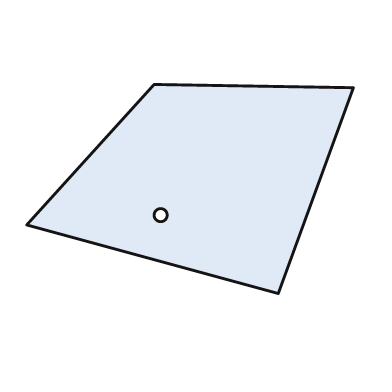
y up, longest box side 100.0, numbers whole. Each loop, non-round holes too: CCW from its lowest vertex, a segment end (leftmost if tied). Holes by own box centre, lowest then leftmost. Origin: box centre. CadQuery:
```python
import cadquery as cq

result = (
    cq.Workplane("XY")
    .moveTo(27.0, -32.0)
    .lineTo(50.0, 31.0)
    .lineTo(-11.0, 32.0)
    .lineTo(-50.0, -11.0)
    .close()
    .moveTo(-9.0, -8.0)
    .circle(2.0)
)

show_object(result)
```